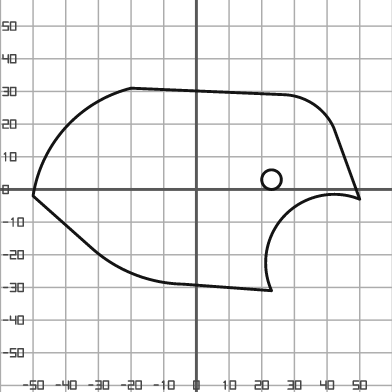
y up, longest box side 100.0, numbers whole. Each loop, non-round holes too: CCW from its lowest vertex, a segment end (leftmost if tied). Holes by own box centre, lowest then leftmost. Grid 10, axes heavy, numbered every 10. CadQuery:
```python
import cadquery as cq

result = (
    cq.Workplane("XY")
    .moveTo(23.0, -31.0)
    .threePointArc((27.0, -8.0), (50.0, -3.0))
    .lineTo(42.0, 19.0)
    .threePointArc((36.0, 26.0), (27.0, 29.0))
    .lineTo(-20.0, 31.0)
    .threePointArc((-40.0, 19.0), (-50.0, -2.0))
    .lineTo(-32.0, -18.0)
    .threePointArc((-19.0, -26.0), (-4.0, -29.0))
    .close()
    .moveTo(23.0, 3.0)
    .circle(3.0)
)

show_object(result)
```